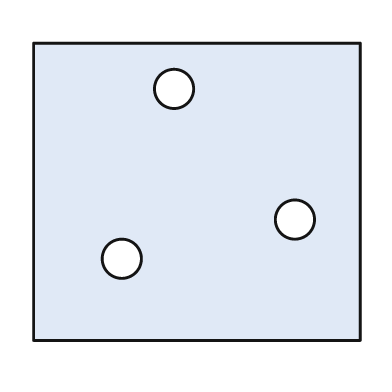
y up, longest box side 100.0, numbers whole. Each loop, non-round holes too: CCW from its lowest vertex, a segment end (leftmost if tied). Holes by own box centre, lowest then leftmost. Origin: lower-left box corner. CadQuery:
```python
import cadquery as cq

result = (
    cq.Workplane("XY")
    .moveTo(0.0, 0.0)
    .lineTo(100.0, 0.0)
    .lineTo(100.0, 91.0)
    .lineTo(0.0, 91.0)
    .close()
    .moveTo(27.0, 25.0)
    .circle(6.0)
    .moveTo(80.0, 37.0)
    .circle(6.0)
    .moveTo(43.0, 77.0)
    .circle(6.0)
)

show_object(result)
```